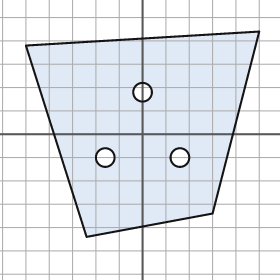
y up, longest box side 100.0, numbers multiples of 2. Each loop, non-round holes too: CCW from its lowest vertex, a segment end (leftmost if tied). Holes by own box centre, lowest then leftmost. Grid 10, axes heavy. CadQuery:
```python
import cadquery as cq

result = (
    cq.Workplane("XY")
    .moveTo(-24.0, -44.0)
    .lineTo(30.0, -34.0)
    .lineTo(50.0, 44.0)
    .lineTo(-50.0, 38.0)
    .close()
    .moveTo(-16.0, -10.0)
    .circle(4.0)
    .moveTo(16.0, -10.0)
    .circle(4.0)
    .moveTo(0.0, 18.0)
    .circle(4.0)
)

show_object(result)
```